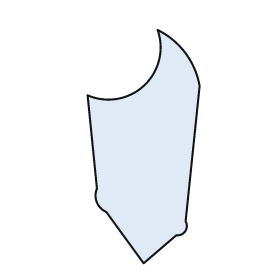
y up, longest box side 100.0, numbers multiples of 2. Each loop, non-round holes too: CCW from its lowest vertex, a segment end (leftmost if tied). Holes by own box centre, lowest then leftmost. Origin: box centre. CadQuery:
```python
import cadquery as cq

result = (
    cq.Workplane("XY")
    .moveTo(0.0, -50.0)
    .lineTo(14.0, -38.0)
    .threePointArc((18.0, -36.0), (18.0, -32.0))
    .lineTo(24.0, 26.0)
    .threePointArc((18.0, 40.0), (6.0, 50.0))
    .threePointArc((0.0, 26.0), (-24.0, 22.0))
    .lineTo(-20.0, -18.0)
    .threePointArc((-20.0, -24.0), (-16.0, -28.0))
    .close()
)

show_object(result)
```